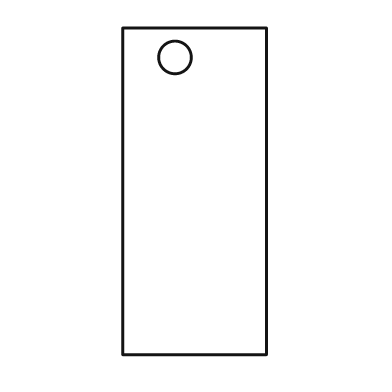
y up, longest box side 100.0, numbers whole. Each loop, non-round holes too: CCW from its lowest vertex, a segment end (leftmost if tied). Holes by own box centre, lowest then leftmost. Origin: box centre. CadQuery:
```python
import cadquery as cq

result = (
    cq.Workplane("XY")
    .moveTo(-22.0, -50.0)
    .lineTo(22.0, -50.0)
    .lineTo(22.0, 50.0)
    .lineTo(-22.0, 50.0)
    .close()
    .moveTo(-6.0, 41.0)
    .circle(5.0)
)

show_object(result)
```